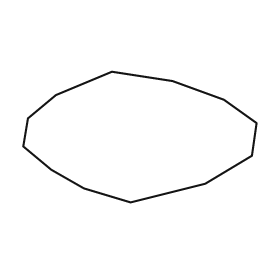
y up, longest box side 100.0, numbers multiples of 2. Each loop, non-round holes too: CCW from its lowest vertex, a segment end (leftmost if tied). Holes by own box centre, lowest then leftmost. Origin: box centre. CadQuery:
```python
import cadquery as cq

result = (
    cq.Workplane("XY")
    .moveTo(-4.0, -28.0)
    .lineTo(28.0, -20.0)
    .lineTo(48.0, -8.0)
    .lineTo(50.0, 6.0)
    .lineTo(36.0, 16.0)
    .lineTo(14.0, 24.0)
    .lineTo(-12.0, 28.0)
    .lineTo(-36.0, 18.0)
    .lineTo(-48.0, 8.0)
    .lineTo(-50.0, -4.0)
    .lineTo(-38.0, -14.0)
    .lineTo(-24.0, -22.0)
    .close()
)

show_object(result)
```